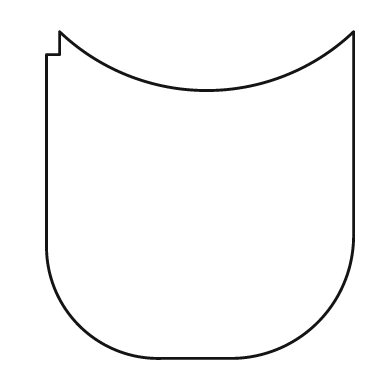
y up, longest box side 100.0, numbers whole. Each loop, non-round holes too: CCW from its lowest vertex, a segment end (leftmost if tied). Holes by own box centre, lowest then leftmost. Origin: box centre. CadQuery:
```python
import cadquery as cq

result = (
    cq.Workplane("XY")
    .moveTo(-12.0, -50.0)
    .lineTo(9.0, -50.0)
    .threePointArc((36.0, -39.0), (47.0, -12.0))
    .lineTo(47.0, 50.0)
    .threePointArc((2.0, 32.0), (-43.0, 50.0))
    .lineTo(-43.0, 43.0)
    .lineTo(-47.0, 43.0)
    .lineTo(-47.0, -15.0)
    .threePointArc((-37.0, -40.0), (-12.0, -50.0))
    .close()
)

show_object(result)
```